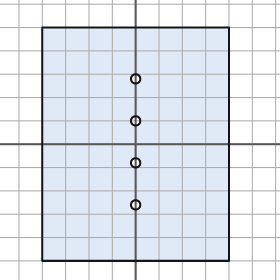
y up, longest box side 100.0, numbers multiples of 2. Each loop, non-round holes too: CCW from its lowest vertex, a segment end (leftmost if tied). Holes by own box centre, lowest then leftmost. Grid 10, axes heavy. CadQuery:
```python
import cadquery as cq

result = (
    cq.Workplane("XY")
    .moveTo(-40.0, -50.0)
    .lineTo(40.0, -50.0)
    .lineTo(40.0, 50.0)
    .lineTo(-40.0, 50.0)
    .close()
    .moveTo(0.0, -26.0)
    .circle(2.0)
    .moveTo(0.0, -8.0)
    .circle(2.0)
    .moveTo(0.0, 10.0)
    .circle(2.0)
    .moveTo(0.0, 28.0)
    .circle(2.0)
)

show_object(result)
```